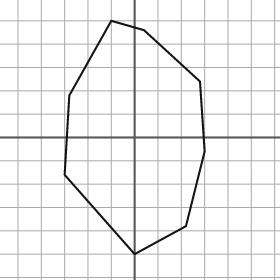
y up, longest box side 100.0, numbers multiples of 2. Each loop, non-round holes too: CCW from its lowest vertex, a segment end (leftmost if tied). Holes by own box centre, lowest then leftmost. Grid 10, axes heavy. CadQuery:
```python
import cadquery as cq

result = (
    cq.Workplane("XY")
    .moveTo(0.0, -50.0)
    .lineTo(22.0, -38.0)
    .lineTo(30.0, -6.0)
    .lineTo(28.0, 24.0)
    .lineTo(4.0, 46.0)
    .lineTo(-10.0, 50.0)
    .lineTo(-28.0, 18.0)
    .lineTo(-30.0, -16.0)
    .close()
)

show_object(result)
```